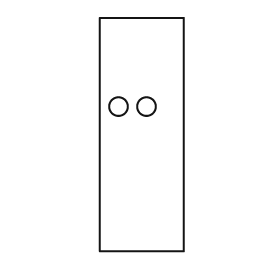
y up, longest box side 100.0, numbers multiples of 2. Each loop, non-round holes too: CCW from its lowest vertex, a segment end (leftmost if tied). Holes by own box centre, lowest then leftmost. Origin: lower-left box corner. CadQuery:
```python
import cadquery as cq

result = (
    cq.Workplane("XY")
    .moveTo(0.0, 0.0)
    .lineTo(36.0, 0.0)
    .lineTo(36.0, 100.0)
    .lineTo(0.0, 100.0)
    .close()
    .moveTo(8.0, 62.0)
    .circle(4.0)
    .moveTo(20.0, 62.0)
    .circle(4.0)
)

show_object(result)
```